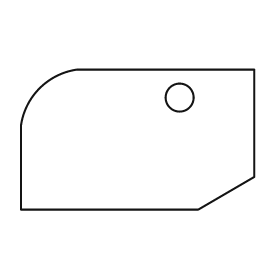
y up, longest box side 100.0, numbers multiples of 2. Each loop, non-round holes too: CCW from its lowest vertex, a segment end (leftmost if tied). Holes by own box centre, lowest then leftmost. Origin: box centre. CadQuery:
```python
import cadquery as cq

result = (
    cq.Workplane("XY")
    .moveTo(-50.0, -30.0)
    .lineTo(26.0, -30.0)
    .lineTo(50.0, -16.0)
    .lineTo(50.0, 30.0)
    .lineTo(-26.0, 30.0)
    .threePointArc((-42.0, 22.0), (-50.0, 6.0))
    .close()
    .moveTo(18.0, 18.0)
    .circle(6.0)
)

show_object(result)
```